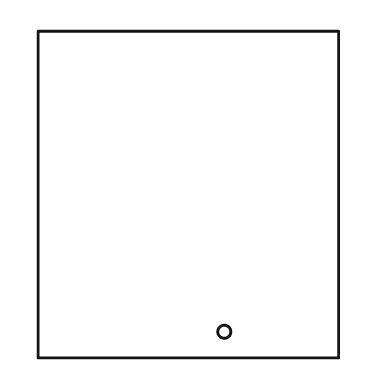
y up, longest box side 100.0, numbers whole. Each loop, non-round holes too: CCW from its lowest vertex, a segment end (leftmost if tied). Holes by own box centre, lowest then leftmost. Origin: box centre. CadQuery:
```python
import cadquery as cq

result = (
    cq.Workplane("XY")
    .moveTo(-46.0, -50.0)
    .lineTo(46.0, -50.0)
    .lineTo(46.0, 50.0)
    .lineTo(-46.0, 50.0)
    .close()
    .moveTo(11.0, -42.0)
    .circle(2.0)
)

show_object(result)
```